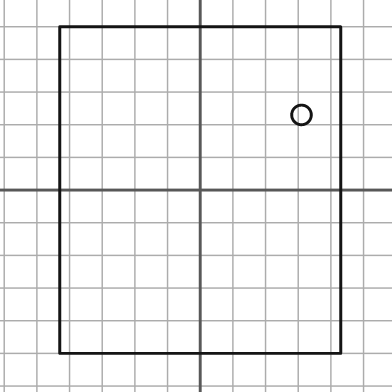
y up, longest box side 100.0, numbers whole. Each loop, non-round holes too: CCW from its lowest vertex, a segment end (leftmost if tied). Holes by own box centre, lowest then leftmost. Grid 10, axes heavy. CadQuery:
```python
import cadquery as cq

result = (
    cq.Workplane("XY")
    .moveTo(-43.0, -50.0)
    .lineTo(43.0, -50.0)
    .lineTo(43.0, 50.0)
    .lineTo(-43.0, 50.0)
    .close()
    .moveTo(31.0, 23.0)
    .circle(3.0)
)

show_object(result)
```